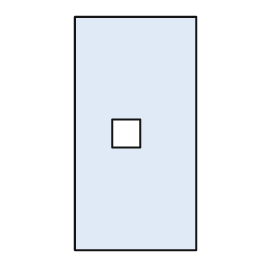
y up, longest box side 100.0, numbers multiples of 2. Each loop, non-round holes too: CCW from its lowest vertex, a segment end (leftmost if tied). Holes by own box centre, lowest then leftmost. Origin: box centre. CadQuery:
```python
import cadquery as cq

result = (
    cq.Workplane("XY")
    .moveTo(-26.0, -50.0)
    .lineTo(26.0, -50.0)
    .lineTo(26.0, 50.0)
    .lineTo(-26.0, 50.0)
    .close()
    .moveTo(-10.0, -6.0)
    .lineTo(2.0, -6.0)
    .lineTo(2.0, 6.0)
    .lineTo(-10.0, 6.0)
    .close()
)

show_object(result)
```